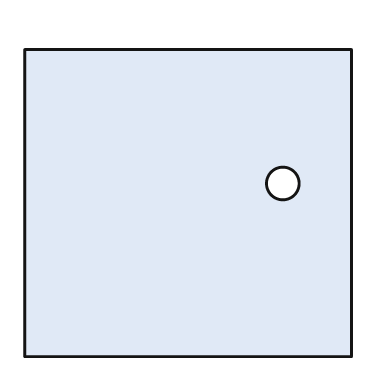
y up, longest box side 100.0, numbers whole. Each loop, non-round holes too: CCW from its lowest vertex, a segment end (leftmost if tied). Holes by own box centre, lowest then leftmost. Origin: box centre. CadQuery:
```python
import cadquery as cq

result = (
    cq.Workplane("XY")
    .moveTo(-50.0, -47.0)
    .lineTo(50.0, -47.0)
    .lineTo(50.0, 47.0)
    .lineTo(-50.0, 47.0)
    .close()
    .moveTo(29.0, 6.0)
    .circle(5.0)
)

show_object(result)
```